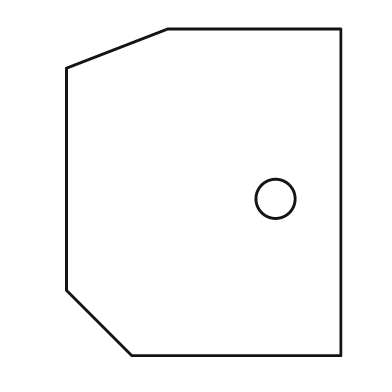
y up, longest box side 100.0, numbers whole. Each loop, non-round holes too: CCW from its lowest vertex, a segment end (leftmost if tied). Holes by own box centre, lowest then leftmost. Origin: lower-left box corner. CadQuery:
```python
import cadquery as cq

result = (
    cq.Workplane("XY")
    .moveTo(20.0, 0.0)
    .lineTo(84.0, 0.0)
    .lineTo(84.0, 100.0)
    .lineTo(31.0, 100.0)
    .lineTo(0.0, 88.0)
    .lineTo(0.0, 20.0)
    .close()
    .moveTo(64.0, 48.0)
    .circle(6.0)
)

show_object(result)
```